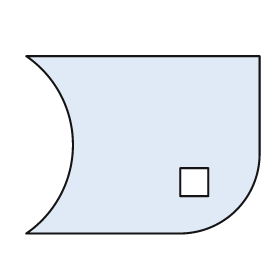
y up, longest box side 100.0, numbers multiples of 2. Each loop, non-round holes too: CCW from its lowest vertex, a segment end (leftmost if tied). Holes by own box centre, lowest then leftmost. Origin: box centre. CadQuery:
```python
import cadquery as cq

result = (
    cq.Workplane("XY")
    .moveTo(-50.0, -38.0)
    .lineTo(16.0, -38.0)
    .threePointArc((40.0, -28.0), (50.0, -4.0))
    .lineTo(50.0, 38.0)
    .lineTo(-50.0, 38.0)
    .threePointArc((-30.0, 0.0), (-50.0, -38.0))
    .close()
    .moveTo(16.0, -22.0)
    .lineTo(28.0, -22.0)
    .lineTo(28.0, -10.0)
    .lineTo(16.0, -10.0)
    .close()
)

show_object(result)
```